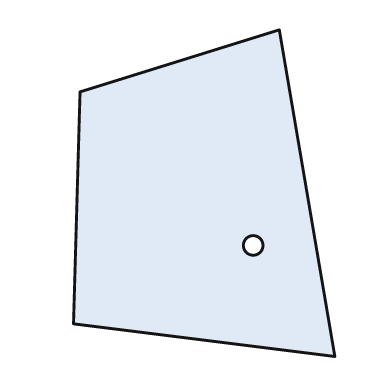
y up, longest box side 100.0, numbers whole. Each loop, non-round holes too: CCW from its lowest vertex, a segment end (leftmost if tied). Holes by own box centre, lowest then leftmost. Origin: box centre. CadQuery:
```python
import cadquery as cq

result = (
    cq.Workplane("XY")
    .moveTo(40.0, -50.0)
    .lineTo(23.0, 50.0)
    .lineTo(-38.0, 31.0)
    .lineTo(-40.0, -40.0)
    .close()
    .moveTo(15.0, -16.0)
    .circle(3.0)
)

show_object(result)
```